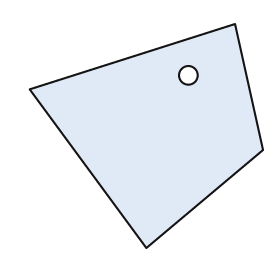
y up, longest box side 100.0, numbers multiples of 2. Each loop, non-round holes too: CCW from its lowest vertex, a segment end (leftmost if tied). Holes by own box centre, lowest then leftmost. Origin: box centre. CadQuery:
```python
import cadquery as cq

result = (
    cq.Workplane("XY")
    .moveTo(0.0, -48.0)
    .lineTo(50.0, -6.0)
    .lineTo(38.0, 48.0)
    .lineTo(-50.0, 20.0)
    .close()
    .moveTo(18.0, 26.0)
    .circle(4.0)
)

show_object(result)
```